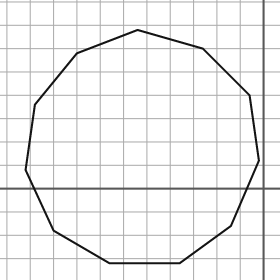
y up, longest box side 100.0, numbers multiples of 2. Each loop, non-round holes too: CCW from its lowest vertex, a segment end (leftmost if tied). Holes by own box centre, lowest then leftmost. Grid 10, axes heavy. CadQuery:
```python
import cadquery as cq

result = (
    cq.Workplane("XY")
    .moveTo(-66.0, -32.0)
    .lineTo(-36.0, -32.0)
    .lineTo(-14.0, -16.0)
    .lineTo(-2.0, 12.0)
    .lineTo(-6.0, 40.0)
    .lineTo(-26.0, 60.0)
    .lineTo(-54.0, 68.0)
    .lineTo(-80.0, 58.0)
    .lineTo(-98.0, 36.0)
    .lineTo(-102.0, 8.0)
    .lineTo(-90.0, -18.0)
    .close()
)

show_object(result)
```